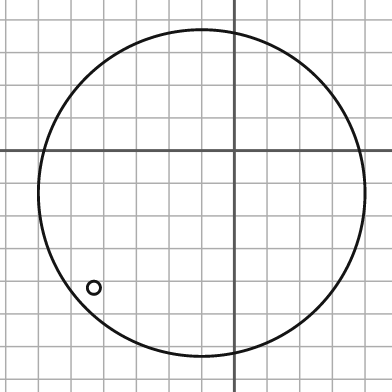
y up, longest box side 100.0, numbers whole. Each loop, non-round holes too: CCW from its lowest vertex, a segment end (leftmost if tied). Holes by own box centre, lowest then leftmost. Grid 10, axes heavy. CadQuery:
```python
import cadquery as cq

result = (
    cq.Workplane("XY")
    .moveTo(-10.0, -13.0)
    .circle(50.0)
    .moveTo(-43.0, -42.0)
    .circle(2.0)
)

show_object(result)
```